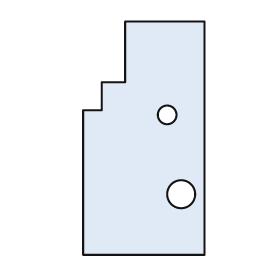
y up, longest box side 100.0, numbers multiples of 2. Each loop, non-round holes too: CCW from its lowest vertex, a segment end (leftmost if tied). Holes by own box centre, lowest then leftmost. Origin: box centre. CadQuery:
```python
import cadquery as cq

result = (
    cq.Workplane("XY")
    .moveTo(-26.0, -50.0)
    .lineTo(26.0, -50.0)
    .lineTo(26.0, 50.0)
    .lineTo(-8.0, 50.0)
    .lineTo(-8.0, 24.0)
    .lineTo(-18.0, 24.0)
    .lineTo(-18.0, 12.0)
    .lineTo(-26.0, 12.0)
    .close()
    .moveTo(16.0, -24.0)
    .circle(6.0)
    .moveTo(10.0, 10.0)
    .circle(4.0)
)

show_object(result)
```